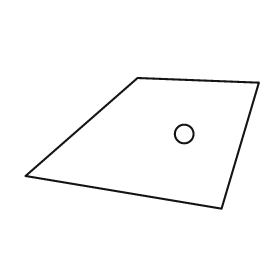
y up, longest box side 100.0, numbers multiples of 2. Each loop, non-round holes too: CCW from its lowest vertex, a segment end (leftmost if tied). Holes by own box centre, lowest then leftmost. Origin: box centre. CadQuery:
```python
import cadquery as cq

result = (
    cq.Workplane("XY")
    .moveTo(34.0, -28.0)
    .lineTo(50.0, 26.0)
    .lineTo(-2.0, 28.0)
    .lineTo(-50.0, -14.0)
    .close()
    .moveTo(18.0, 4.0)
    .circle(4.0)
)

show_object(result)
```